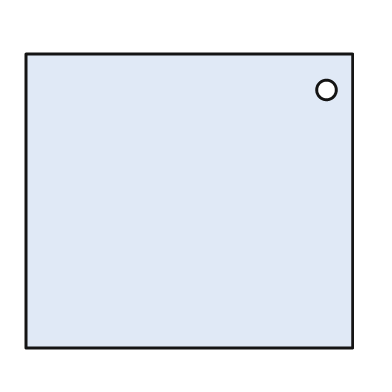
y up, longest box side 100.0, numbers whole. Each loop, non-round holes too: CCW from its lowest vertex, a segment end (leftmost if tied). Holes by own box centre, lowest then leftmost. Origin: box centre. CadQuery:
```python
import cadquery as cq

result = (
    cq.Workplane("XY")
    .moveTo(-50.0, -45.0)
    .lineTo(50.0, -45.0)
    .lineTo(50.0, 45.0)
    .lineTo(-50.0, 45.0)
    .close()
    .moveTo(42.0, 34.0)
    .circle(3.0)
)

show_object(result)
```